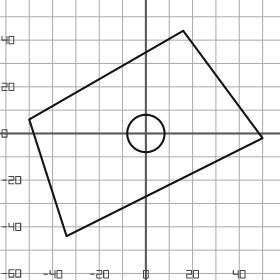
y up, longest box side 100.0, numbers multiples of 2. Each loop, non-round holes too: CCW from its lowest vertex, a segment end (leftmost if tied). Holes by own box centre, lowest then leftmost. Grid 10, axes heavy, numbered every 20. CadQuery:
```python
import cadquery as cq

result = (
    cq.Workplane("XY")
    .moveTo(-34.0, -44.0)
    .lineTo(50.0, -2.0)
    .lineTo(16.0, 44.0)
    .lineTo(-50.0, 6.0)
    .close()
    .moveTo(0.0, 0.0)
    .circle(8.0)
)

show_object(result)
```